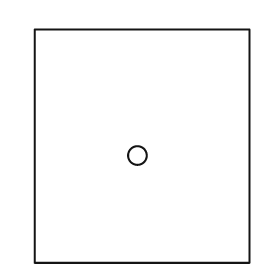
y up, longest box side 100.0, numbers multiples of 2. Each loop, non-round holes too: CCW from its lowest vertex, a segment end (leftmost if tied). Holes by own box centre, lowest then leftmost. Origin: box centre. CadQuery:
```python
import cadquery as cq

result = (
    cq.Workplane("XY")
    .moveTo(-46.0, -50.0)
    .lineTo(46.0, -50.0)
    .lineTo(46.0, 50.0)
    .lineTo(-46.0, 50.0)
    .close()
    .moveTo(-2.0, -4.0)
    .circle(4.0)
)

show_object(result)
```